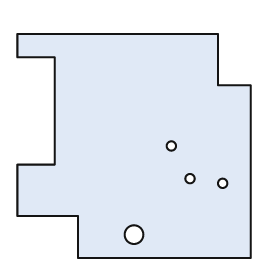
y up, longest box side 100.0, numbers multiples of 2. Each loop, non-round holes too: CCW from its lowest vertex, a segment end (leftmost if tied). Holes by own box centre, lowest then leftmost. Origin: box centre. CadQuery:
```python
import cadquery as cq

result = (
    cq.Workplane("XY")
    .moveTo(-24.0, -48.0)
    .lineTo(50.0, -48.0)
    .lineTo(50.0, 26.0)
    .lineTo(36.0, 26.0)
    .lineTo(36.0, 48.0)
    .lineTo(-50.0, 48.0)
    .lineTo(-50.0, 38.0)
    .lineTo(-34.0, 38.0)
    .lineTo(-34.0, -8.0)
    .lineTo(-50.0, -8.0)
    .lineTo(-50.0, -30.0)
    .lineTo(-24.0, -30.0)
    .close()
    .moveTo(0.0, -38.0)
    .circle(4.0)
    .moveTo(38.0, -16.0)
    .circle(2.0)
    .moveTo(24.0, -14.0)
    .circle(2.0)
    .moveTo(16.0, 0.0)
    .circle(2.0)
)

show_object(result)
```